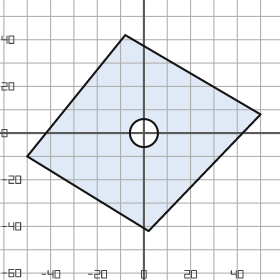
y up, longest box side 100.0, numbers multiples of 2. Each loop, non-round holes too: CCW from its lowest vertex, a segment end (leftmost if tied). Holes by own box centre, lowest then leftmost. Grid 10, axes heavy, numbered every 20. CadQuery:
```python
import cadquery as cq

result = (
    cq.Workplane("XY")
    .moveTo(2.0, -42.0)
    .lineTo(50.0, 8.0)
    .lineTo(-8.0, 42.0)
    .lineTo(-50.0, -10.0)
    .close()
    .moveTo(0.0, 0.0)
    .circle(6.0)
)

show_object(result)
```